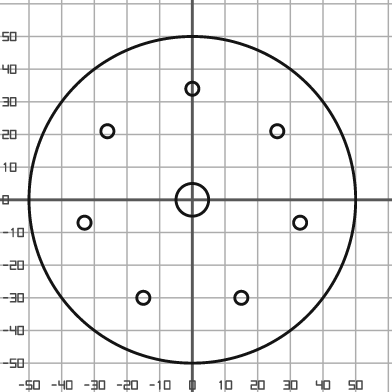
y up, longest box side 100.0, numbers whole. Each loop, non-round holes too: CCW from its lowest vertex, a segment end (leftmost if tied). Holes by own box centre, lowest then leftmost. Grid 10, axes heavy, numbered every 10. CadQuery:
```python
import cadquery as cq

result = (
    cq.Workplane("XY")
    .moveTo(0.0, 0.0)
    .circle(50.0)
    .moveTo(-15.0, -30.0)
    .circle(2.0)
    .moveTo(15.0, -30.0)
    .circle(2.0)
    .moveTo(-33.0, -7.0)
    .circle(2.0)
    .moveTo(33.0, -7.0)
    .circle(2.0)
    .moveTo(0.0, 0.0)
    .circle(5.0)
    .moveTo(-26.0, 21.0)
    .circle(2.0)
    .moveTo(26.0, 21.0)
    .circle(2.0)
    .moveTo(0.0, 34.0)
    .circle(2.0)
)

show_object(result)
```